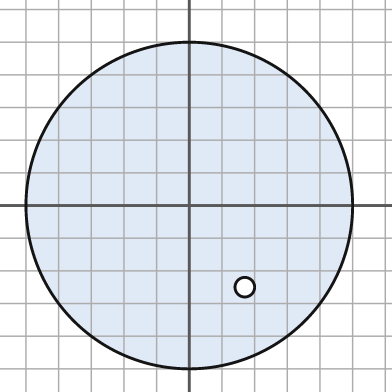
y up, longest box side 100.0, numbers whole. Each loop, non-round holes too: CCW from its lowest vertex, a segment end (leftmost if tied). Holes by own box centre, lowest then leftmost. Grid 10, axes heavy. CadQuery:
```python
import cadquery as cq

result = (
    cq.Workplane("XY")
    .moveTo(0.0, 0.0)
    .circle(50.0)
    .moveTo(17.0, -25.0)
    .circle(3.0)
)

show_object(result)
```